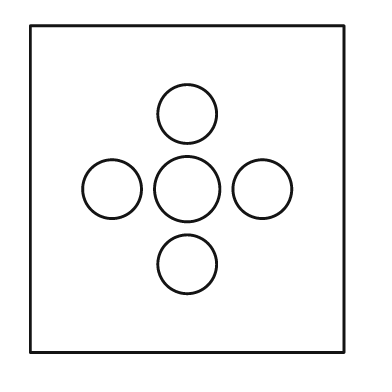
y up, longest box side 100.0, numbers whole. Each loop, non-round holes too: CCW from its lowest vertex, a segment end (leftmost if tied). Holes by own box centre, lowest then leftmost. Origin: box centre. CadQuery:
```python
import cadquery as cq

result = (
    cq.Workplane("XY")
    .moveTo(-48.0, -50.0)
    .lineTo(48.0, -50.0)
    .lineTo(48.0, 50.0)
    .lineTo(-48.0, 50.0)
    .close()
    .moveTo(0.0, -23.0)
    .circle(9.0)
    .moveTo(-23.0, 0.0)
    .circle(9.0)
    .moveTo(0.0, 0.0)
    .circle(10.0)
    .moveTo(23.0, 0.0)
    .circle(9.0)
    .moveTo(0.0, 23.0)
    .circle(9.0)
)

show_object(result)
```